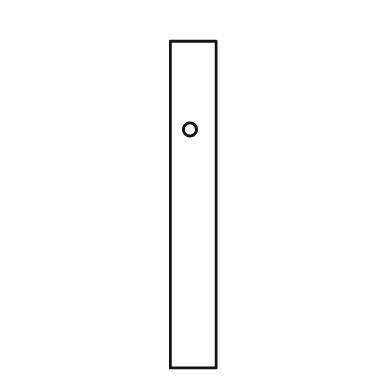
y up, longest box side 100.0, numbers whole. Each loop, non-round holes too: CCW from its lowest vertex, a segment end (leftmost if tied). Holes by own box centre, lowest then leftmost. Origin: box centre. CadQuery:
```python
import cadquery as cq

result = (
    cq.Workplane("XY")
    .moveTo(-7.0, -50.0)
    .lineTo(7.0, -50.0)
    .lineTo(7.0, 50.0)
    .lineTo(-7.0, 50.0)
    .close()
    .moveTo(-1.0, 23.0)
    .circle(2.0)
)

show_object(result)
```